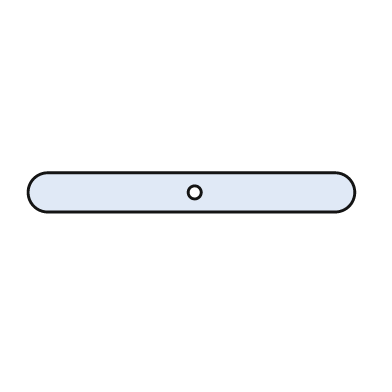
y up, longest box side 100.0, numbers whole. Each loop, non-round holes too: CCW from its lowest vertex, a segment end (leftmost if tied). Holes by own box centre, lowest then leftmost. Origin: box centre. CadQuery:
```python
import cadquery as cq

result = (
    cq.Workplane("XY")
    .moveTo(-44.0, -6.0)
    .lineTo(44.0, -6.0)
    .threePointArc((50.0, 0.0), (44.0, 6.0))
    .lineTo(-44.0, 6.0)
    .threePointArc((-50.0, 0.0), (-44.0, -6.0))
    .close()
    .moveTo(1.0, 0.0)
    .circle(2.0)
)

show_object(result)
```